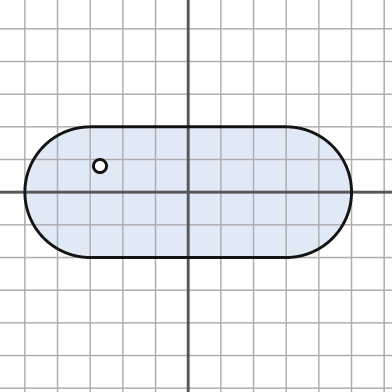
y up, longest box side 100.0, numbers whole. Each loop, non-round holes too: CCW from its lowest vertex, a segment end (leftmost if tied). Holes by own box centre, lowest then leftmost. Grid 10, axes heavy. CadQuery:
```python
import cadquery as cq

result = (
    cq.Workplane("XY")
    .moveTo(-30.0, -20.0)
    .lineTo(30.0, -20.0)
    .threePointArc((50.0, 0.0), (30.0, 20.0))
    .lineTo(-30.0, 20.0)
    .threePointArc((-50.0, 0.0), (-30.0, -20.0))
    .close()
    .moveTo(-27.0, 8.0)
    .circle(2.0)
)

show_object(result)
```